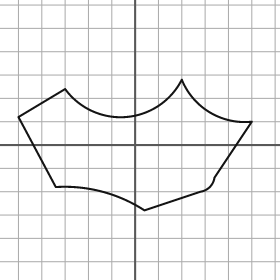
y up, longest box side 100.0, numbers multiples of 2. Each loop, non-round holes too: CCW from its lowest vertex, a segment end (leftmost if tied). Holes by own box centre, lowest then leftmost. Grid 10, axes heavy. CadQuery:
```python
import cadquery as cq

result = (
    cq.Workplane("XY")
    .moveTo(4.0, -28.0)
    .lineTo(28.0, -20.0)
    .threePointArc((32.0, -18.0), (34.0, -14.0))
    .lineTo(50.0, 10.0)
    .threePointArc((32.0, 14.0), (20.0, 28.0))
    .threePointArc((-4.0, 12.0), (-30.0, 24.0))
    .lineTo(-50.0, 12.0)
    .lineTo(-34.0, -18.0)
    .threePointArc((-14.0, -20.0), (4.0, -28.0))
    .close()
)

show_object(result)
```